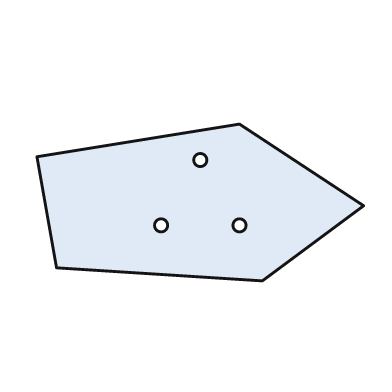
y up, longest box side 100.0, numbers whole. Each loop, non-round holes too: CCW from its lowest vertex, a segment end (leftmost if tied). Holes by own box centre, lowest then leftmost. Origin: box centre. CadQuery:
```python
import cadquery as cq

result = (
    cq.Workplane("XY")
    .moveTo(19.0, -24.0)
    .lineTo(50.0, -1.0)
    .lineTo(12.0, 24.0)
    .lineTo(-50.0, 14.0)
    .lineTo(-44.0, -20.0)
    .close()
    .moveTo(-12.0, -7.0)
    .circle(2.0)
    .moveTo(12.0, -7.0)
    .circle(2.0)
    .moveTo(0.0, 13.0)
    .circle(2.0)
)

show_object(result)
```